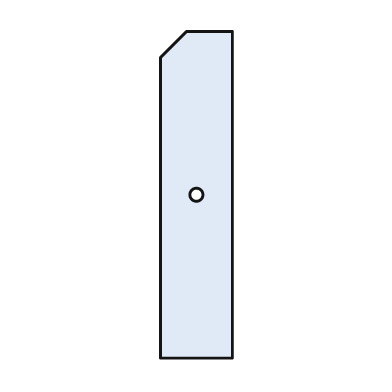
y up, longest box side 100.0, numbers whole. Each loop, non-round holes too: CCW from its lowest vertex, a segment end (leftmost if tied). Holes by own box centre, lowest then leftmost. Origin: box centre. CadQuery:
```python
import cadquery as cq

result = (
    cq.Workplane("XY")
    .moveTo(-11.0, -50.0)
    .lineTo(11.0, -50.0)
    .lineTo(11.0, 50.0)
    .lineTo(-3.0, 50.0)
    .lineTo(-11.0, 42.0)
    .close()
    .moveTo(0.0, 0.0)
    .circle(2.0)
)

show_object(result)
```